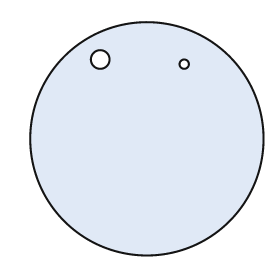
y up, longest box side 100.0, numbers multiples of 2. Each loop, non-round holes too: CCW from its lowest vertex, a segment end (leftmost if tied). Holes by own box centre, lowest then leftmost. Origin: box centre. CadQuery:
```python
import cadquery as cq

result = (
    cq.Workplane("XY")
    .moveTo(0.0, 0.0)
    .circle(50.0)
    .moveTo(16.0, 32.0)
    .circle(2.0)
    .moveTo(-20.0, 34.0)
    .circle(4.0)
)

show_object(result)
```